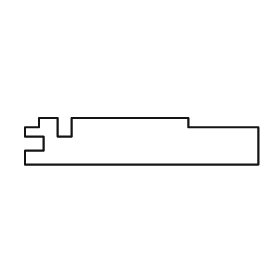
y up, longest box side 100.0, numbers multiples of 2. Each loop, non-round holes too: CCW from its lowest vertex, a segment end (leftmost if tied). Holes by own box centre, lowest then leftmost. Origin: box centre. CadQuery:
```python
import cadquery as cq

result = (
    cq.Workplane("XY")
    .moveTo(-50.0, -10.0)
    .lineTo(50.0, -10.0)
    .lineTo(50.0, 6.0)
    .lineTo(20.0, 6.0)
    .lineTo(20.0, 10.0)
    .lineTo(-30.0, 10.0)
    .lineTo(-30.0, 2.0)
    .lineTo(-36.0, 2.0)
    .lineTo(-36.0, 10.0)
    .lineTo(-44.0, 10.0)
    .lineTo(-44.0, 6.0)
    .lineTo(-50.0, 6.0)
    .lineTo(-50.0, 2.0)
    .lineTo(-42.0, 2.0)
    .lineTo(-42.0, -4.0)
    .lineTo(-50.0, -4.0)
    .close()
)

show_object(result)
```